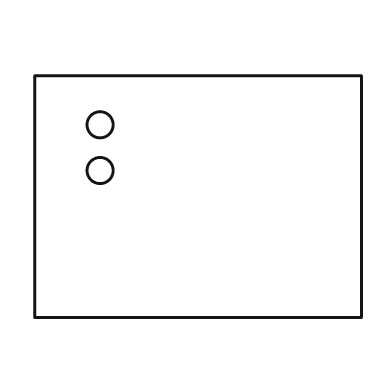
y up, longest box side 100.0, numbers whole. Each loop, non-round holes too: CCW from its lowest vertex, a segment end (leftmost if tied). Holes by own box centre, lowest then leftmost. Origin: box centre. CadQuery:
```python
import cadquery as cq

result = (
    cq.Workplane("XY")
    .moveTo(-50.0, -37.0)
    .lineTo(50.0, -37.0)
    .lineTo(50.0, 37.0)
    .lineTo(-50.0, 37.0)
    .close()
    .moveTo(-30.0, 8.0)
    .circle(4.0)
    .moveTo(-30.0, 22.0)
    .circle(4.0)
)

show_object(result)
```